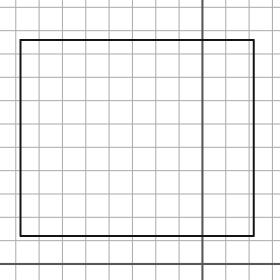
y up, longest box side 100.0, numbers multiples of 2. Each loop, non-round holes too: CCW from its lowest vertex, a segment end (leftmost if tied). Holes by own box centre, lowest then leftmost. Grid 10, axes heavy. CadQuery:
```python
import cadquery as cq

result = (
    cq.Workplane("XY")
    .moveTo(-78.0, 12.0)
    .lineTo(22.0, 12.0)
    .lineTo(22.0, 96.0)
    .lineTo(-78.0, 96.0)
    .close()
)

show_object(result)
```